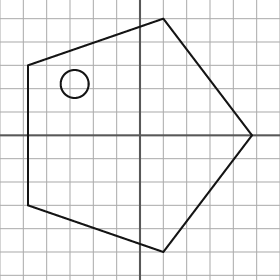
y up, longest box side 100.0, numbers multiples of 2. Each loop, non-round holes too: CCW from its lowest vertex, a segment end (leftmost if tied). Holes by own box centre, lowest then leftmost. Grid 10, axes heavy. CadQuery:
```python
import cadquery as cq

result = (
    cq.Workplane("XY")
    .moveTo(10.0, -50.0)
    .lineTo(48.0, 0.0)
    .lineTo(10.0, 50.0)
    .lineTo(-48.0, 30.0)
    .lineTo(-48.0, -30.0)
    .close()
    .moveTo(-28.0, 22.0)
    .circle(6.0)
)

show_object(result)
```